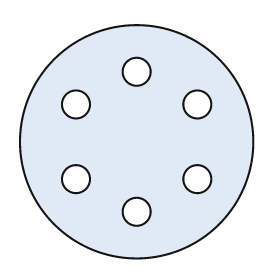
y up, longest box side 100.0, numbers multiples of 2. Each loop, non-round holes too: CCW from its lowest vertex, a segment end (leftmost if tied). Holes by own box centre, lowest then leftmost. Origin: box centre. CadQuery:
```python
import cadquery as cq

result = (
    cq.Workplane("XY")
    .moveTo(0.0, 0.0)
    .circle(50.0)
    .moveTo(0.0, -30.0)
    .circle(6.0)
    .moveTo(-26.0, -16.0)
    .circle(6.0)
    .moveTo(26.0, -16.0)
    .circle(6.0)
    .moveTo(-26.0, 16.0)
    .circle(6.0)
    .moveTo(26.0, 16.0)
    .circle(6.0)
    .moveTo(0.0, 30.0)
    .circle(6.0)
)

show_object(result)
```